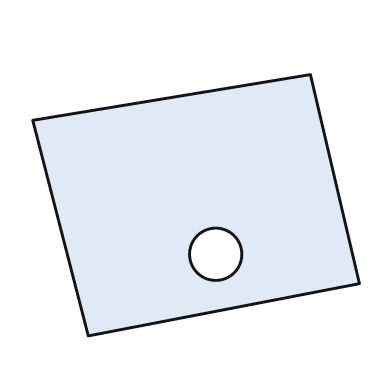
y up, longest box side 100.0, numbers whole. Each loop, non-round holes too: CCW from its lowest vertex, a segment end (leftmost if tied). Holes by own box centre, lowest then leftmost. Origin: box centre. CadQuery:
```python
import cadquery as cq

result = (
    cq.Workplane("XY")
    .moveTo(-33.0, -40.0)
    .lineTo(50.0, -24.0)
    .lineTo(35.0, 40.0)
    .lineTo(-50.0, 26.0)
    .close()
    .moveTo(6.0, -15.0)
    .circle(8.0)
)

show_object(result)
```